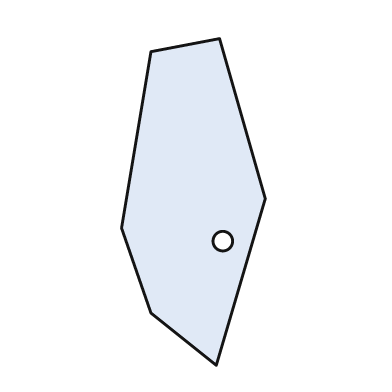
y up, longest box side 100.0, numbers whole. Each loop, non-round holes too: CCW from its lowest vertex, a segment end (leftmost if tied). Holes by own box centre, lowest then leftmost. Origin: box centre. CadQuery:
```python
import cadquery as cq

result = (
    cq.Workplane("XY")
    .moveTo(7.0, -50.0)
    .lineTo(22.0, 1.0)
    .lineTo(8.0, 50.0)
    .lineTo(-13.0, 46.0)
    .lineTo(-22.0, -8.0)
    .lineTo(-13.0, -34.0)
    .close()
    .moveTo(9.0, -12.0)
    .circle(3.0)
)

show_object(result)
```